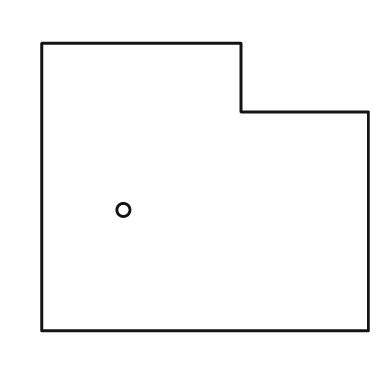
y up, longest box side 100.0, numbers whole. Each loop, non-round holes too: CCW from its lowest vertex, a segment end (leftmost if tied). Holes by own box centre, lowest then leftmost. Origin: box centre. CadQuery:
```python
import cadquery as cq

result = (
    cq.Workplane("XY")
    .moveTo(-50.0, -44.0)
    .lineTo(50.0, -44.0)
    .lineTo(50.0, 23.0)
    .lineTo(11.0, 23.0)
    .lineTo(11.0, 44.0)
    .lineTo(-50.0, 44.0)
    .close()
    .moveTo(-25.0, -7.0)
    .circle(2.0)
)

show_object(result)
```